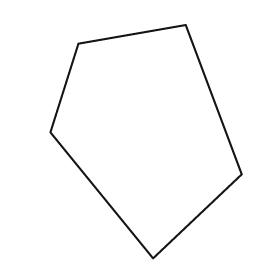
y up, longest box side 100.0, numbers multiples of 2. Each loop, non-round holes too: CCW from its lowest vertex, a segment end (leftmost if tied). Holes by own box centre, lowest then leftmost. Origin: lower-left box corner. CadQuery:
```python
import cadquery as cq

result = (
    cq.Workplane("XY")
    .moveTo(44.0, 0.0)
    .lineTo(82.0, 36.0)
    .lineTo(58.0, 100.0)
    .lineTo(12.0, 92.0)
    .lineTo(0.0, 54.0)
    .close()
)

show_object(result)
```